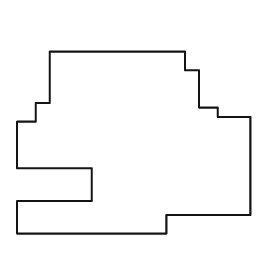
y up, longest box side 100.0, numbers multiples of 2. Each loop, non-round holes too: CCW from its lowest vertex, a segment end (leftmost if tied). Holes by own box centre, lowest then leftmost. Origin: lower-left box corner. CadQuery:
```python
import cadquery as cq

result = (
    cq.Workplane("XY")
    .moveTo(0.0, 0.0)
    .lineTo(64.0, 0.0)
    .lineTo(64.0, 8.0)
    .lineTo(100.0, 8.0)
    .lineTo(100.0, 50.0)
    .lineTo(86.0, 50.0)
    .lineTo(86.0, 54.0)
    .lineTo(78.0, 54.0)
    .lineTo(78.0, 70.0)
    .lineTo(72.0, 70.0)
    .lineTo(72.0, 78.0)
    .lineTo(14.0, 78.0)
    .lineTo(14.0, 56.0)
    .lineTo(8.0, 56.0)
    .lineTo(8.0, 48.0)
    .lineTo(0.0, 48.0)
    .lineTo(0.0, 28.0)
    .lineTo(32.0, 28.0)
    .lineTo(32.0, 14.0)
    .lineTo(0.0, 14.0)
    .close()
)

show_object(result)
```